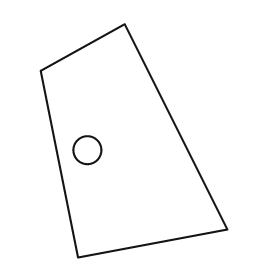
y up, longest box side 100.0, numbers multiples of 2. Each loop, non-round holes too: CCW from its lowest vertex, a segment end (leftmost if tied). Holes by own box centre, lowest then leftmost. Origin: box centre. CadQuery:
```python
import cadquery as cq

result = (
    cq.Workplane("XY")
    .moveTo(-24.0, -50.0)
    .lineTo(40.0, -38.0)
    .lineTo(-4.0, 50.0)
    .lineTo(-40.0, 30.0)
    .close()
    .moveTo(-20.0, -4.0)
    .circle(6.0)
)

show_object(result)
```